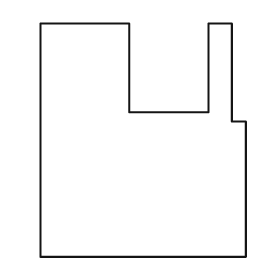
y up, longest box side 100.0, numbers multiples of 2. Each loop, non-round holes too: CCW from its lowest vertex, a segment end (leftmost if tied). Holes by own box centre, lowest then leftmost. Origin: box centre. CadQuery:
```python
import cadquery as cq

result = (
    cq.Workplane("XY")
    .moveTo(-44.0, -50.0)
    .lineTo(44.0, -50.0)
    .lineTo(44.0, 8.0)
    .lineTo(38.0, 8.0)
    .lineTo(38.0, 50.0)
    .lineTo(28.0, 50.0)
    .lineTo(28.0, 12.0)
    .lineTo(-6.0, 12.0)
    .lineTo(-6.0, 50.0)
    .lineTo(-44.0, 50.0)
    .close()
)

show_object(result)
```